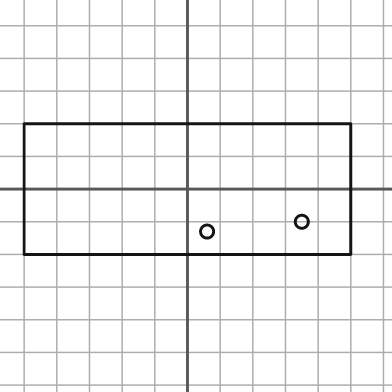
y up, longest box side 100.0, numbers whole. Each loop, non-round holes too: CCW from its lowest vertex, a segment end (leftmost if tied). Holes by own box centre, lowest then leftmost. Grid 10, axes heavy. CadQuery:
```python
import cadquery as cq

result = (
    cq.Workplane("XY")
    .moveTo(-50.0, -20.0)
    .lineTo(50.0, -20.0)
    .lineTo(50.0, 20.0)
    .lineTo(-50.0, 20.0)
    .close()
    .moveTo(6.0, -13.0)
    .circle(2.0)
    .moveTo(35.0, -10.0)
    .circle(2.0)
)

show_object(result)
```